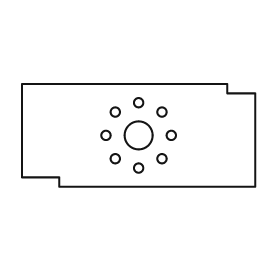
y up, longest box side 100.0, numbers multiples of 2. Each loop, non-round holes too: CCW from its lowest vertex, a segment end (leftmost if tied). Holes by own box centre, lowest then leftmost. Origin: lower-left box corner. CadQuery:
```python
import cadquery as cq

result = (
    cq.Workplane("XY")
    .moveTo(16.0, 0.0)
    .lineTo(100.0, 0.0)
    .lineTo(100.0, 40.0)
    .lineTo(88.0, 40.0)
    .lineTo(88.0, 44.0)
    .lineTo(0.0, 44.0)
    .lineTo(0.0, 4.0)
    .lineTo(16.0, 4.0)
    .close()
    .moveTo(50.0, 8.0)
    .circle(2.0)
    .moveTo(40.0, 12.0)
    .circle(2.0)
    .moveTo(60.0, 12.0)
    .circle(2.0)
    .moveTo(36.0, 22.0)
    .circle(2.0)
    .moveTo(50.0, 22.0)
    .circle(6.0)
    .moveTo(64.0, 22.0)
    .circle(2.0)
    .moveTo(40.0, 32.0)
    .circle(2.0)
    .moveTo(60.0, 32.0)
    .circle(2.0)
    .moveTo(50.0, 36.0)
    .circle(2.0)
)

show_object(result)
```